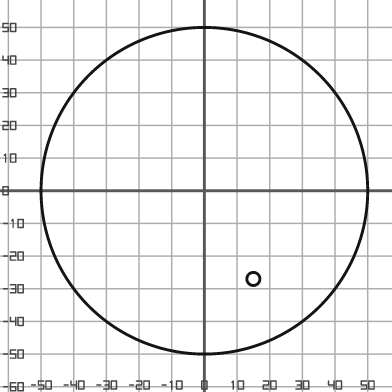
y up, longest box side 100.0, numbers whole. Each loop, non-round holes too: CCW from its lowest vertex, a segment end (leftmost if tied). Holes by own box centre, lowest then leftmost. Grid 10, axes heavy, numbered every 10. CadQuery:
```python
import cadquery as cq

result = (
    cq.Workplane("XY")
    .moveTo(0.0, 0.0)
    .circle(50.0)
    .moveTo(15.0, -27.0)
    .circle(2.0)
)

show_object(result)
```